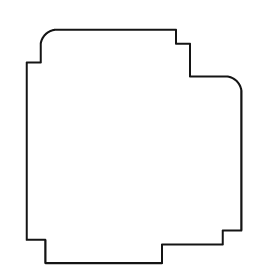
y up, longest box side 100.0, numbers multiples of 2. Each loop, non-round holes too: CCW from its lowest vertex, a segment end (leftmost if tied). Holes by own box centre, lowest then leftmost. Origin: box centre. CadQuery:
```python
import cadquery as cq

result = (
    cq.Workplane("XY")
    .moveTo(-38.0, -50.0)
    .lineTo(12.0, -50.0)
    .lineTo(12.0, -42.0)
    .lineTo(38.0, -42.0)
    .lineTo(38.0, -36.0)
    .lineTo(46.0, -36.0)
    .lineTo(46.0, 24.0)
    .threePointArc((44.0, 28.0), (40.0, 30.0))
    .lineTo(24.0, 30.0)
    .lineTo(24.0, 44.0)
    .lineTo(18.0, 44.0)
    .lineTo(18.0, 50.0)
    .lineTo(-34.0, 50.0)
    .threePointArc((-38.0, 48.0), (-40.0, 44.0))
    .lineTo(-40.0, 36.0)
    .lineTo(-46.0, 36.0)
    .lineTo(-46.0, -40.0)
    .lineTo(-38.0, -40.0)
    .close()
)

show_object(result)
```